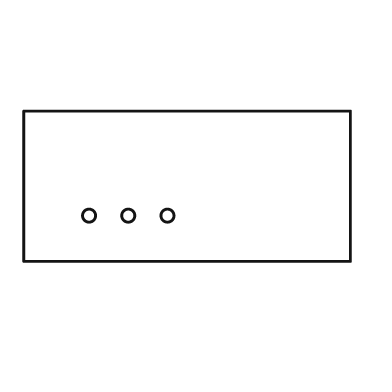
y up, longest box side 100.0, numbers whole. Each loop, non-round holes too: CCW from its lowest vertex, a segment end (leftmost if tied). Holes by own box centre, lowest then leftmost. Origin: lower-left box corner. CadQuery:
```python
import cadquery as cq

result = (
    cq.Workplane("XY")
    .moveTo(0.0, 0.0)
    .lineTo(100.0, 0.0)
    .lineTo(100.0, 46.0)
    .lineTo(0.0, 46.0)
    .close()
    .moveTo(20.0, 14.0)
    .circle(2.0)
    .moveTo(32.0, 14.0)
    .circle(2.0)
    .moveTo(44.0, 14.0)
    .circle(2.0)
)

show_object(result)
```